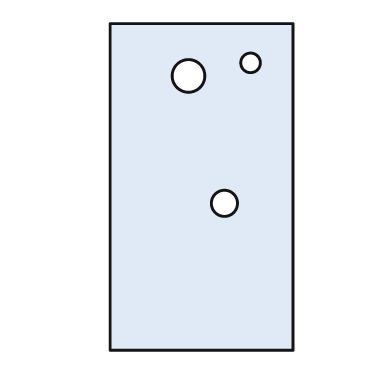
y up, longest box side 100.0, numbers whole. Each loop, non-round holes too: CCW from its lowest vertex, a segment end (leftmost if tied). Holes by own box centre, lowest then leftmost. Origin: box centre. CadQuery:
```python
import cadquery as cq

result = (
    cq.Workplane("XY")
    .moveTo(-28.0, -50.0)
    .lineTo(28.0, -50.0)
    .lineTo(28.0, 50.0)
    .lineTo(-28.0, 50.0)
    .close()
    .moveTo(7.0, -5.0)
    .circle(4.0)
    .moveTo(-4.0, 34.0)
    .circle(5.0)
    .moveTo(15.0, 38.0)
    .circle(3.0)
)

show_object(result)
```